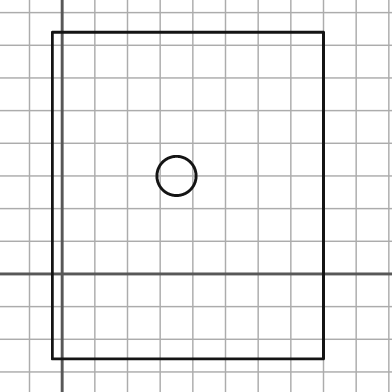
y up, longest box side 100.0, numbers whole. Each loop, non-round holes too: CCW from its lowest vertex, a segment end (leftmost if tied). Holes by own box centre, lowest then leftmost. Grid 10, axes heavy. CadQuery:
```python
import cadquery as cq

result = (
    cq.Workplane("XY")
    .moveTo(-3.0, -26.0)
    .lineTo(80.0, -26.0)
    .lineTo(80.0, 74.0)
    .lineTo(-3.0, 74.0)
    .close()
    .moveTo(35.0, 30.0)
    .circle(6.0)
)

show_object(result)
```